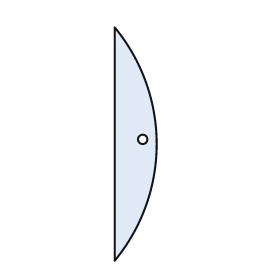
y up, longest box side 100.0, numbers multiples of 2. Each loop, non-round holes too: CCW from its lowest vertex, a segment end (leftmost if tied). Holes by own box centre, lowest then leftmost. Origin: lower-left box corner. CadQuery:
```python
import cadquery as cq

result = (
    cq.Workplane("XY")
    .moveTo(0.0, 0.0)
    .threePointArc((18.0, 50.0), (0.0, 100.0))
    .close()
    .moveTo(12.0, 52.0)
    .circle(2.0)
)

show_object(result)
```